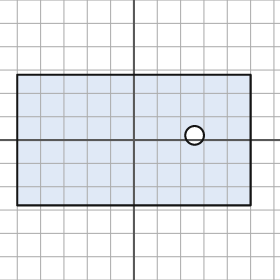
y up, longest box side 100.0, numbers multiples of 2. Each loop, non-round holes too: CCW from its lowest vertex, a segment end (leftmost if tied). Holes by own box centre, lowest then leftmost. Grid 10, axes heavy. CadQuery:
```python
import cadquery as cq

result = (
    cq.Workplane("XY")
    .moveTo(-50.0, -28.0)
    .lineTo(50.0, -28.0)
    .lineTo(50.0, 28.0)
    .lineTo(-50.0, 28.0)
    .close()
    .moveTo(26.0, 2.0)
    .circle(4.0)
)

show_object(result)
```